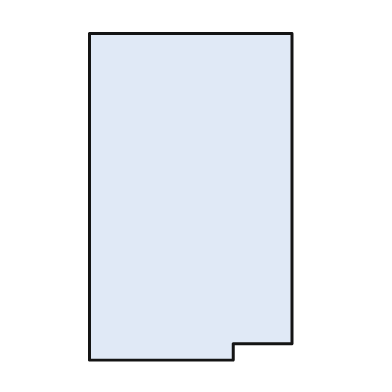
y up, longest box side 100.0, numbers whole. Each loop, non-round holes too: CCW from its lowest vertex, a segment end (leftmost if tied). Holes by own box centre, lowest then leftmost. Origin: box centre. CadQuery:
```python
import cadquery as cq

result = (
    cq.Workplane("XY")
    .moveTo(-31.0, -50.0)
    .lineTo(13.0, -50.0)
    .lineTo(13.0, -45.0)
    .lineTo(31.0, -45.0)
    .lineTo(31.0, 50.0)
    .lineTo(-31.0, 50.0)
    .close()
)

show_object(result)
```